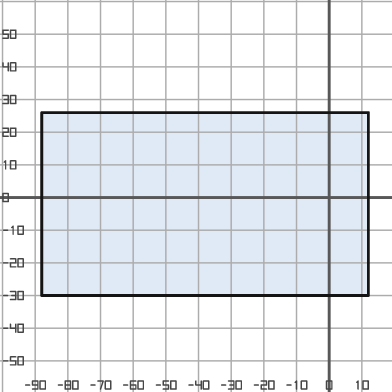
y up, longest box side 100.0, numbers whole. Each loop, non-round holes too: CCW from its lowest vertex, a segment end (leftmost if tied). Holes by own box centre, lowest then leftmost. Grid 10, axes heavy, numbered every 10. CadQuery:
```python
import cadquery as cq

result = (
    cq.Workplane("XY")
    .moveTo(-88.0, -30.0)
    .lineTo(12.0, -30.0)
    .lineTo(12.0, 26.0)
    .lineTo(-88.0, 26.0)
    .close()
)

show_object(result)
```